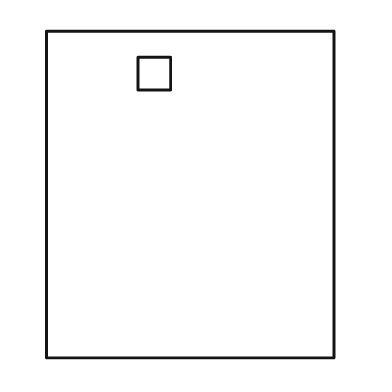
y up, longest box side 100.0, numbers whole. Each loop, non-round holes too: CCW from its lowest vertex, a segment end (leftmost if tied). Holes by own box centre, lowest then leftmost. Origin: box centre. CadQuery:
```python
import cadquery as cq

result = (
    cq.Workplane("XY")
    .moveTo(-44.0, -50.0)
    .lineTo(44.0, -50.0)
    .lineTo(44.0, 50.0)
    .lineTo(-44.0, 50.0)
    .close()
    .moveTo(-16.0, 32.0)
    .lineTo(-6.0, 32.0)
    .lineTo(-6.0, 42.0)
    .lineTo(-16.0, 42.0)
    .close()
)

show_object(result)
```